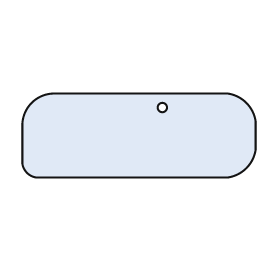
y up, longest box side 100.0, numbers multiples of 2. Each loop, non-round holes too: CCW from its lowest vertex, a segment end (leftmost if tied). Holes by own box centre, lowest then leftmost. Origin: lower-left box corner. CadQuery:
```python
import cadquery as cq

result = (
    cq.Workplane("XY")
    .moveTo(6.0, 0.0)
    .lineTo(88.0, 0.0)
    .threePointArc((96.0, 4.0), (100.0, 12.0))
    .lineTo(100.0, 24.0)
    .threePointArc((96.0, 32.0), (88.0, 36.0))
    .lineTo(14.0, 36.0)
    .threePointArc((4.0, 32.0), (0.0, 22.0))
    .lineTo(0.0, 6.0)
    .threePointArc((2.0, 2.0), (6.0, 0.0))
    .close()
    .moveTo(60.0, 30.0)
    .circle(2.0)
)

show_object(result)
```